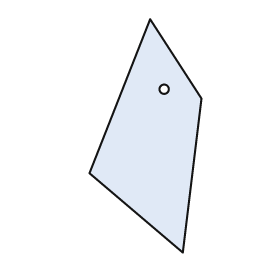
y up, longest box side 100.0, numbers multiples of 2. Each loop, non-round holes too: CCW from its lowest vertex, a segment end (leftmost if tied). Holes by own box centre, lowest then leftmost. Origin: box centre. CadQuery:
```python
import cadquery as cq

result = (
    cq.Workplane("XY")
    .moveTo(16.0, -50.0)
    .lineTo(24.0, 16.0)
    .lineTo(2.0, 50.0)
    .lineTo(-24.0, -16.0)
    .close()
    .moveTo(8.0, 20.0)
    .circle(2.0)
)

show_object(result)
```